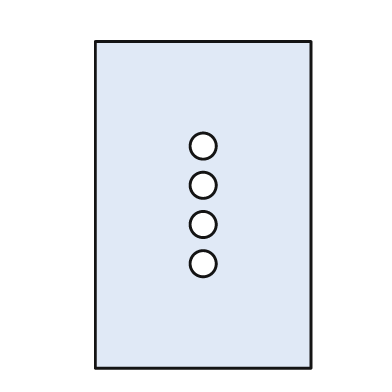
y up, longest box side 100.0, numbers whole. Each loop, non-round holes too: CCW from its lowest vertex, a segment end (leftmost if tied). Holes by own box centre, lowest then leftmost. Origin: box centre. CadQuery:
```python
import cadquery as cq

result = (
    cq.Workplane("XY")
    .moveTo(-33.0, -50.0)
    .lineTo(33.0, -50.0)
    .lineTo(33.0, 50.0)
    .lineTo(-33.0, 50.0)
    .close()
    .moveTo(0.0, -18.0)
    .circle(4.0)
    .moveTo(0.0, -6.0)
    .circle(4.0)
    .moveTo(0.0, 6.0)
    .circle(4.0)
    .moveTo(0.0, 18.0)
    .circle(4.0)
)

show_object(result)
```